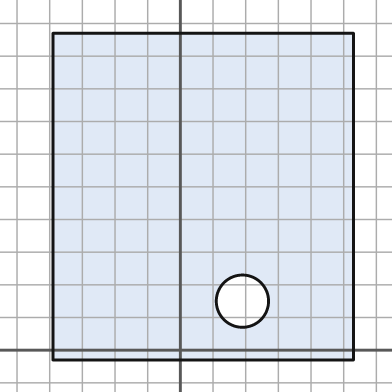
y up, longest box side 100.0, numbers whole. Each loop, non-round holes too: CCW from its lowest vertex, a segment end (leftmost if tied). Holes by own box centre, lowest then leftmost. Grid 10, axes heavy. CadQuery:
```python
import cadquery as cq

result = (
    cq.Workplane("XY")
    .moveTo(-39.0, -3.0)
    .lineTo(53.0, -3.0)
    .lineTo(53.0, 97.0)
    .lineTo(-39.0, 97.0)
    .close()
    .moveTo(19.0, 15.0)
    .circle(8.0)
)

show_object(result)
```